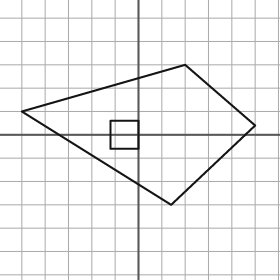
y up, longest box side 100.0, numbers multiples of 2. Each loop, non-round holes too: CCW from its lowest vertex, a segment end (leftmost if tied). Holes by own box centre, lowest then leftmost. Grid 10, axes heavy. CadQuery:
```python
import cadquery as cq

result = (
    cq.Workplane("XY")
    .moveTo(14.0, -30.0)
    .lineTo(50.0, 4.0)
    .lineTo(20.0, 30.0)
    .lineTo(-50.0, 10.0)
    .close()
    .moveTo(-12.0, -6.0)
    .lineTo(0.0, -6.0)
    .lineTo(0.0, 6.0)
    .lineTo(-12.0, 6.0)
    .close()
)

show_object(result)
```